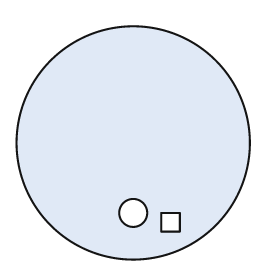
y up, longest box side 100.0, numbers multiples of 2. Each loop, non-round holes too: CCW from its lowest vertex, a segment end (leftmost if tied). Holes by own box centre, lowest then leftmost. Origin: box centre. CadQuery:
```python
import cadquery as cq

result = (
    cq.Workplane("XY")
    .moveTo(0.0, 0.0)
    .circle(50.0)
    .moveTo(12.0, -38.0)
    .lineTo(20.0, -38.0)
    .lineTo(20.0, -30.0)
    .lineTo(12.0, -30.0)
    .close()
    .moveTo(0.0, -30.0)
    .circle(6.0)
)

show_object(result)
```